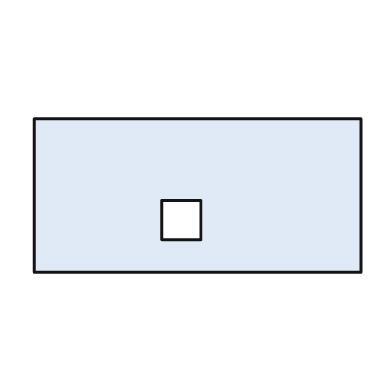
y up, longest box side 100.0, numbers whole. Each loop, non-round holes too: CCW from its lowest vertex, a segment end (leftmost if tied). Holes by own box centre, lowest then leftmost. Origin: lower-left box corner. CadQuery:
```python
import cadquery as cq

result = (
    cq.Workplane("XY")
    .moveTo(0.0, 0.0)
    .lineTo(100.0, 0.0)
    .lineTo(100.0, 47.0)
    .lineTo(0.0, 47.0)
    .close()
    .moveTo(39.0, 10.0)
    .lineTo(51.0, 10.0)
    .lineTo(51.0, 22.0)
    .lineTo(39.0, 22.0)
    .close()
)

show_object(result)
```